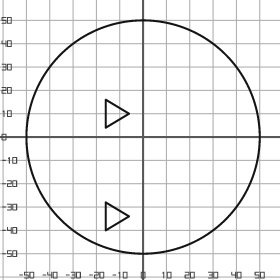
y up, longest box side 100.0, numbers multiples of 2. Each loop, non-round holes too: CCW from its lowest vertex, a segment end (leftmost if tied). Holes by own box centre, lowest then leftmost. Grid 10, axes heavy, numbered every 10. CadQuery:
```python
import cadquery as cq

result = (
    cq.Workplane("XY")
    .moveTo(0.0, 0.0)
    .circle(50.0)
    .moveTo(-16.0, -40.0)
    .lineTo(-6.0, -34.0)
    .lineTo(-16.0, -28.0)
    .close()
    .moveTo(-16.0, 4.0)
    .lineTo(-6.0, 10.0)
    .lineTo(-16.0, 16.0)
    .close()
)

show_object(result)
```